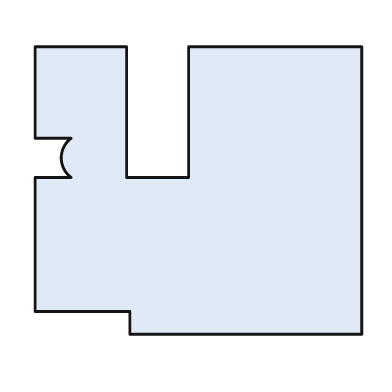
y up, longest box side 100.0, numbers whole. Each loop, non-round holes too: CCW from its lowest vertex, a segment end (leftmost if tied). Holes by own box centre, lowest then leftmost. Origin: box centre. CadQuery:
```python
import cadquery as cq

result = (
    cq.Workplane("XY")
    .moveTo(-21.0, -44.0)
    .lineTo(50.0, -44.0)
    .lineTo(50.0, 44.0)
    .lineTo(-3.0, 44.0)
    .lineTo(-3.0, 4.0)
    .lineTo(-22.0, 4.0)
    .lineTo(-22.0, 44.0)
    .lineTo(-50.0, 44.0)
    .lineTo(-50.0, 16.0)
    .lineTo(-39.0, 16.0)
    .threePointArc((-42.0, 10.0), (-39.0, 4.0))
    .lineTo(-50.0, 4.0)
    .lineTo(-50.0, -37.0)
    .lineTo(-21.0, -37.0)
    .close()
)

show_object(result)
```